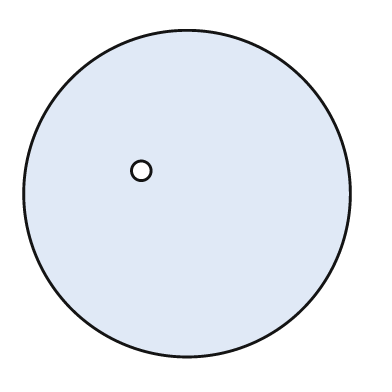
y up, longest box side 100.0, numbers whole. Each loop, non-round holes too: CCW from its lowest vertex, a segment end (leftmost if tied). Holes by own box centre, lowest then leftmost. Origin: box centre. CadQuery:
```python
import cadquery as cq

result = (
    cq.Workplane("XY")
    .moveTo(0.0, 0.0)
    .circle(50.0)
    .moveTo(-14.0, 7.0)
    .circle(3.0)
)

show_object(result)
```